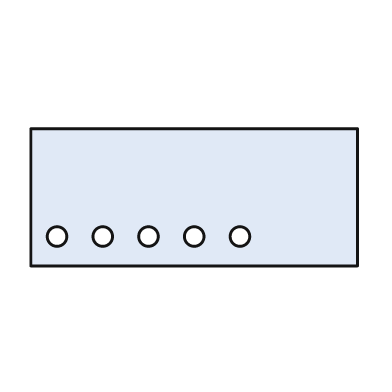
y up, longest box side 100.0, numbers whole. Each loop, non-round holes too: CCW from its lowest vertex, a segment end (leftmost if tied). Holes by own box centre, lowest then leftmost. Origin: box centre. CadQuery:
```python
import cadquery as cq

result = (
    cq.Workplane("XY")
    .moveTo(-50.0, -21.0)
    .lineTo(50.0, -21.0)
    .lineTo(50.0, 21.0)
    .lineTo(-50.0, 21.0)
    .close()
    .moveTo(-42.0, -12.0)
    .circle(3.0)
    .moveTo(-28.0, -12.0)
    .circle(3.0)
    .moveTo(-14.0, -12.0)
    .circle(3.0)
    .moveTo(0.0, -12.0)
    .circle(3.0)
    .moveTo(14.0, -12.0)
    .circle(3.0)
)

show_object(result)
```